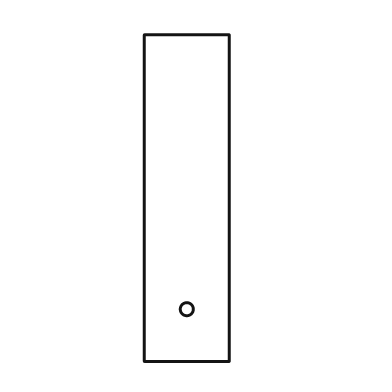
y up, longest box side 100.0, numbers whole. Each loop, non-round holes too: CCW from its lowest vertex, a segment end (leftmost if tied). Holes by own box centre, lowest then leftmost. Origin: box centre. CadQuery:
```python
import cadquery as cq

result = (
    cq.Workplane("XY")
    .moveTo(-13.0, -50.0)
    .lineTo(13.0, -50.0)
    .lineTo(13.0, 50.0)
    .lineTo(-13.0, 50.0)
    .close()
    .moveTo(0.0, -34.0)
    .circle(2.0)
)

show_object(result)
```